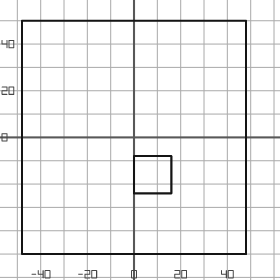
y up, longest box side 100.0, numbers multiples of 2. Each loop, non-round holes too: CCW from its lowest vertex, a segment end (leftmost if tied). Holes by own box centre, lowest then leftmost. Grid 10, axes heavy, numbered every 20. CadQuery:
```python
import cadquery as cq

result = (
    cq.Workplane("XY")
    .moveTo(-48.0, -50.0)
    .lineTo(48.0, -50.0)
    .lineTo(48.0, 50.0)
    .lineTo(-48.0, 50.0)
    .close()
    .moveTo(0.0, -24.0)
    .lineTo(16.0, -24.0)
    .lineTo(16.0, -8.0)
    .lineTo(0.0, -8.0)
    .close()
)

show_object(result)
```